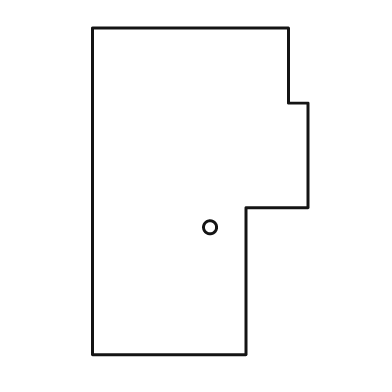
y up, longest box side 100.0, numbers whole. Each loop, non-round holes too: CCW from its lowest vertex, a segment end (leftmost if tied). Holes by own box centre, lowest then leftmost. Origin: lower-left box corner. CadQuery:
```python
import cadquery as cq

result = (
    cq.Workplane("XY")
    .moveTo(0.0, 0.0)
    .lineTo(47.0, 0.0)
    .lineTo(47.0, 45.0)
    .lineTo(66.0, 45.0)
    .lineTo(66.0, 77.0)
    .lineTo(60.0, 77.0)
    .lineTo(60.0, 100.0)
    .lineTo(0.0, 100.0)
    .close()
    .moveTo(36.0, 39.0)
    .circle(2.0)
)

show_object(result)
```